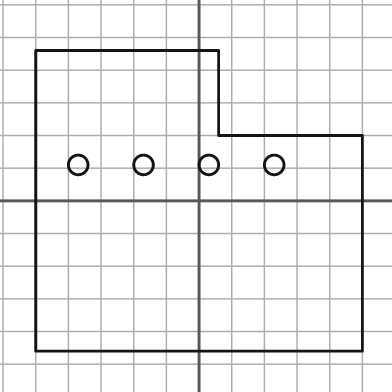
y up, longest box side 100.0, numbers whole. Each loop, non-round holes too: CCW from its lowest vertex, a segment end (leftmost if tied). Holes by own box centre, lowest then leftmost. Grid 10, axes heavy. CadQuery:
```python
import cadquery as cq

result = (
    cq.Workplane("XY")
    .moveTo(-50.0, -46.0)
    .lineTo(50.0, -46.0)
    .lineTo(50.0, 20.0)
    .lineTo(6.0, 20.0)
    .lineTo(6.0, 46.0)
    .lineTo(-50.0, 46.0)
    .close()
    .moveTo(-37.0, 11.0)
    .circle(3.0)
    .moveTo(-17.0, 11.0)
    .circle(3.0)
    .moveTo(3.0, 11.0)
    .circle(3.0)
    .moveTo(23.0, 11.0)
    .circle(3.0)
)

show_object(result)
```